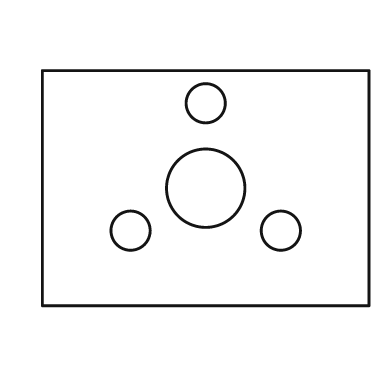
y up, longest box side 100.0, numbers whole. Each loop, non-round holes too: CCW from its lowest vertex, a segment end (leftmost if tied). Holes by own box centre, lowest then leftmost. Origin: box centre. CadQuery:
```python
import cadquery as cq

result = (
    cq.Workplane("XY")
    .moveTo(-50.0, -36.0)
    .lineTo(50.0, -36.0)
    .lineTo(50.0, 36.0)
    .lineTo(-50.0, 36.0)
    .close()
    .moveTo(-23.0, -13.0)
    .circle(6.0)
    .moveTo(23.0, -13.0)
    .circle(6.0)
    .moveTo(0.0, 0.0)
    .circle(12.0)
    .moveTo(0.0, 26.0)
    .circle(6.0)
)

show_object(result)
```